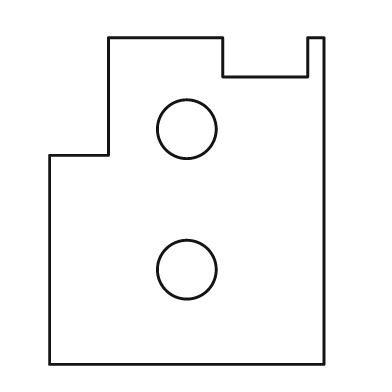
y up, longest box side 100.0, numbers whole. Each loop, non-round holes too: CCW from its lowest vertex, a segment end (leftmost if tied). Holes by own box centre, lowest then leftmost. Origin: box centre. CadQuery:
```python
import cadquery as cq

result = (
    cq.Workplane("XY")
    .moveTo(-42.0, -50.0)
    .lineTo(42.0, -50.0)
    .lineTo(42.0, 50.0)
    .lineTo(37.0, 50.0)
    .lineTo(37.0, 38.0)
    .lineTo(11.0, 38.0)
    .lineTo(11.0, 50.0)
    .lineTo(-24.0, 50.0)
    .lineTo(-24.0, 14.0)
    .lineTo(-42.0, 14.0)
    .close()
    .moveTo(0.0, -21.0)
    .circle(9.0)
    .moveTo(0.0, 22.0)
    .circle(9.0)
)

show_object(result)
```